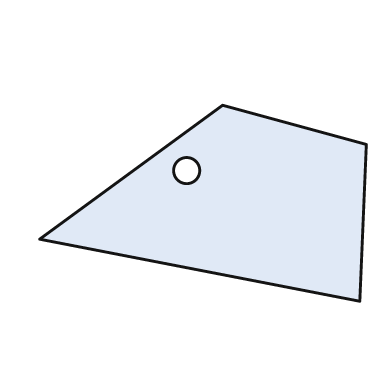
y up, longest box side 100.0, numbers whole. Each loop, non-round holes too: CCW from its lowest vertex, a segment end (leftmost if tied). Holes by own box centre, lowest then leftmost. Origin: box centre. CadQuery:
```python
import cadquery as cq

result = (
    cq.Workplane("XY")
    .moveTo(48.0, -30.0)
    .lineTo(50.0, 18.0)
    .lineTo(6.0, 30.0)
    .lineTo(-50.0, -11.0)
    .close()
    .moveTo(-5.0, 10.0)
    .circle(4.0)
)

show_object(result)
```